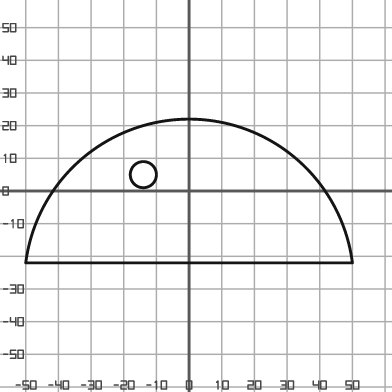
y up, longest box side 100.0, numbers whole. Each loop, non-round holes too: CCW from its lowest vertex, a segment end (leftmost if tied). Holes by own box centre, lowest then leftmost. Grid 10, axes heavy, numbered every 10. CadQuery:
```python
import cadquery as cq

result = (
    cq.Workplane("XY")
    .moveTo(-50.0, -22.0)
    .lineTo(50.0, -22.0)
    .threePointArc((0.0, 22.0), (-50.0, -22.0))
    .close()
    .moveTo(-14.0, 5.0)
    .circle(4.0)
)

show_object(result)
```